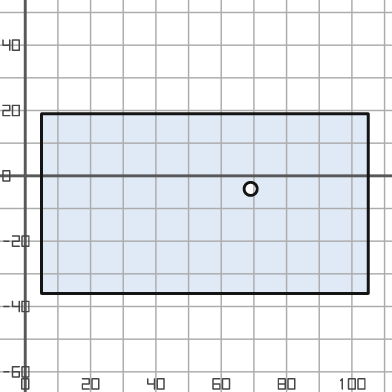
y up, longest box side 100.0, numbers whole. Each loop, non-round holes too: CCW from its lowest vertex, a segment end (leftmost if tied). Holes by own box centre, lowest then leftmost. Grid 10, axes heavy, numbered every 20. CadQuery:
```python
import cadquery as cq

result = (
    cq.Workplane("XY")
    .moveTo(5.0, -36.0)
    .lineTo(105.0, -36.0)
    .lineTo(105.0, 19.0)
    .lineTo(5.0, 19.0)
    .close()
    .moveTo(69.0, -4.0)
    .circle(2.0)
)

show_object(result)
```